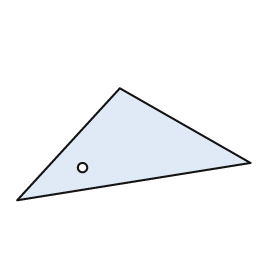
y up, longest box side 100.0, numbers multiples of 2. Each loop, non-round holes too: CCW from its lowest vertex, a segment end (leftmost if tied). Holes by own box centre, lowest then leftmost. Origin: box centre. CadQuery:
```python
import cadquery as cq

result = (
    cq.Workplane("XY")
    .moveTo(-50.0, -24.0)
    .lineTo(50.0, -8.0)
    .lineTo(-6.0, 24.0)
    .close()
    .moveTo(-22.0, -10.0)
    .circle(2.0)
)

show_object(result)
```